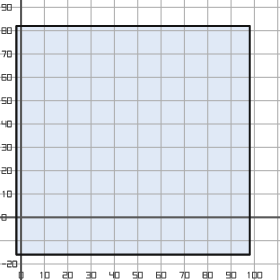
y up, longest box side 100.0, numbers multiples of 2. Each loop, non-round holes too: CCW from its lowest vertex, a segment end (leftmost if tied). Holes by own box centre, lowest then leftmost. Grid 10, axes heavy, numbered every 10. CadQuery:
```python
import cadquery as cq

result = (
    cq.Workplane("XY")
    .moveTo(-2.0, -16.0)
    .lineTo(98.0, -16.0)
    .lineTo(98.0, 82.0)
    .lineTo(-2.0, 82.0)
    .close()
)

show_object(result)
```